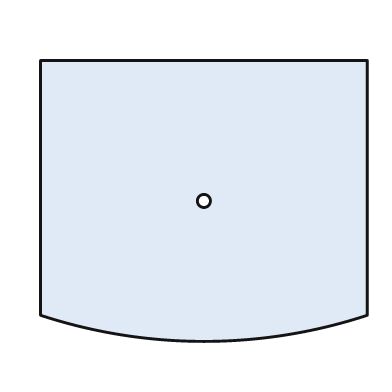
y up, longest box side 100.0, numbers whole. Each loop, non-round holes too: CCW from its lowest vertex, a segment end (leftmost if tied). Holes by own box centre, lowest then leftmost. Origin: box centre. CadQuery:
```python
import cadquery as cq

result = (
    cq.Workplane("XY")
    .moveTo(-50.0, -35.0)
    .threePointArc((0.0, -43.0), (50.0, -35.0))
    .lineTo(50.0, 43.0)
    .lineTo(-50.0, 43.0)
    .close()
    .moveTo(0.0, 0.0)
    .circle(2.0)
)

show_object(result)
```